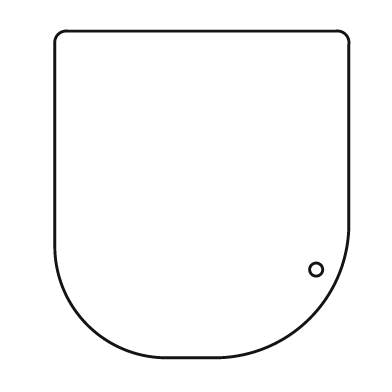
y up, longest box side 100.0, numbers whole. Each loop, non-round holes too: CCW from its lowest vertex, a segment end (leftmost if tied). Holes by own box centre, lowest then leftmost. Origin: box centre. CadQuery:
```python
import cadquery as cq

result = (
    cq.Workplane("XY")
    .moveTo(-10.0, -50.0)
    .lineTo(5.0, -50.0)
    .threePointArc((33.0, -38.0), (45.0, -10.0))
    .lineTo(45.0, 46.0)
    .threePointArc((44.0, 49.0), (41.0, 50.0))
    .lineTo(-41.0, 50.0)
    .threePointArc((-44.0, 49.0), (-45.0, 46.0))
    .lineTo(-45.0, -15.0)
    .threePointArc((-35.0, -40.0), (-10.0, -50.0))
    .close()
    .moveTo(35.0, -23.0)
    .circle(2.0)
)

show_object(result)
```